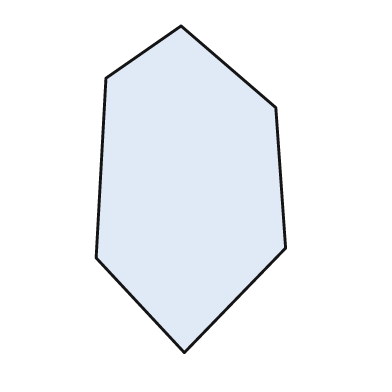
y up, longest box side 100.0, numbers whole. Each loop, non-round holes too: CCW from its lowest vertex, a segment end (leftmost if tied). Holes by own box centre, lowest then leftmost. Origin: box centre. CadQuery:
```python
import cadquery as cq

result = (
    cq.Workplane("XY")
    .moveTo(-2.0, -50.0)
    .lineTo(29.0, -18.0)
    .lineTo(26.0, 25.0)
    .lineTo(-3.0, 50.0)
    .lineTo(-26.0, 34.0)
    .lineTo(-29.0, -21.0)
    .close()
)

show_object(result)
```